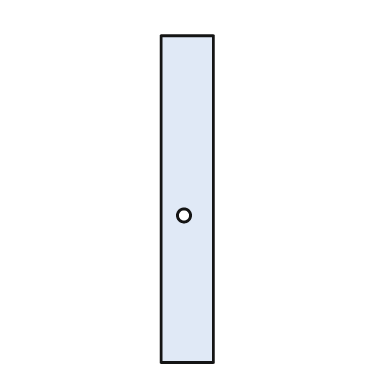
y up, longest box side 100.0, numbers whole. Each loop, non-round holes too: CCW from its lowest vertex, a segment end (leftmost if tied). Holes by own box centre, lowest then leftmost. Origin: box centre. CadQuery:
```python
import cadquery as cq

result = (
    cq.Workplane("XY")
    .moveTo(-8.0, -50.0)
    .lineTo(8.0, -50.0)
    .lineTo(8.0, 50.0)
    .lineTo(-8.0, 50.0)
    .close()
    .moveTo(-1.0, -5.0)
    .circle(2.0)
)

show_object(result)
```